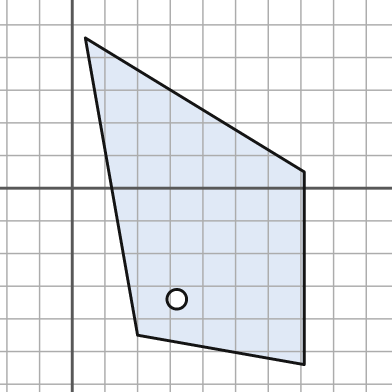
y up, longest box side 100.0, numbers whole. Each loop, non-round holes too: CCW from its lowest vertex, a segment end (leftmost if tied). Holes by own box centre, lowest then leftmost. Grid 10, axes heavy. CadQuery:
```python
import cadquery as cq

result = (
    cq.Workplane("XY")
    .moveTo(71.0, -54.0)
    .lineTo(71.0, 5.0)
    .lineTo(4.0, 46.0)
    .lineTo(20.0, -45.0)
    .close()
    .moveTo(32.0, -34.0)
    .circle(3.0)
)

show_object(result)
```